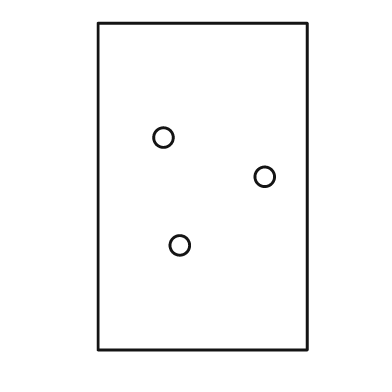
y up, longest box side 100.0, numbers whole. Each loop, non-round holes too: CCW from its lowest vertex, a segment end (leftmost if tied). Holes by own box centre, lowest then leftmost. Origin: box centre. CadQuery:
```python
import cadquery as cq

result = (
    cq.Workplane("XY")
    .moveTo(-32.0, -50.0)
    .lineTo(32.0, -50.0)
    .lineTo(32.0, 50.0)
    .lineTo(-32.0, 50.0)
    .close()
    .moveTo(-7.0, -18.0)
    .circle(3.0)
    .moveTo(19.0, 3.0)
    .circle(3.0)
    .moveTo(-12.0, 15.0)
    .circle(3.0)
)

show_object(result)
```